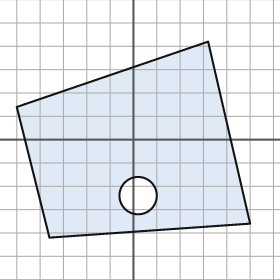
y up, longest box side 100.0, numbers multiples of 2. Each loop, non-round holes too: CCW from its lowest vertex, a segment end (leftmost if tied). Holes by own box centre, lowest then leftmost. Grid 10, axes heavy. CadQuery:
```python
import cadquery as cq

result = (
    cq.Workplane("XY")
    .moveTo(-36.0, -42.0)
    .lineTo(50.0, -36.0)
    .lineTo(32.0, 42.0)
    .lineTo(-50.0, 14.0)
    .close()
    .moveTo(2.0, -24.0)
    .circle(8.0)
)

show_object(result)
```